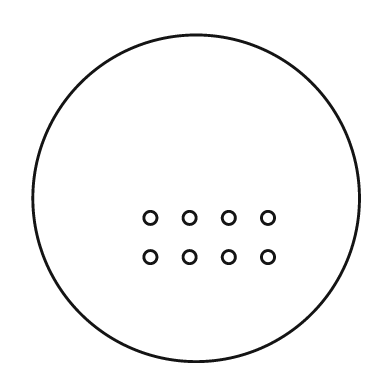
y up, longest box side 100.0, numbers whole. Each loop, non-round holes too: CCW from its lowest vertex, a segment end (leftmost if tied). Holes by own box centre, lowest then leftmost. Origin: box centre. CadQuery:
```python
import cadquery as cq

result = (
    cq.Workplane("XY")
    .moveTo(0.0, 0.0)
    .circle(50.0)
    .moveTo(-14.0, -18.0)
    .circle(2.0)
    .moveTo(-2.0, -18.0)
    .circle(2.0)
    .moveTo(10.0, -18.0)
    .circle(2.0)
    .moveTo(22.0, -18.0)
    .circle(2.0)
    .moveTo(-14.0, -6.0)
    .circle(2.0)
    .moveTo(-2.0, -6.0)
    .circle(2.0)
    .moveTo(10.0, -6.0)
    .circle(2.0)
    .moveTo(22.0, -6.0)
    .circle(2.0)
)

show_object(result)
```